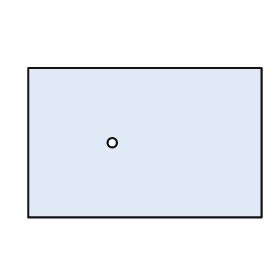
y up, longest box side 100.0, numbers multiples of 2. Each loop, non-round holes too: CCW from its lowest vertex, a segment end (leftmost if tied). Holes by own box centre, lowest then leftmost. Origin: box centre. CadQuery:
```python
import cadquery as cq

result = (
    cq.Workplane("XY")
    .moveTo(-50.0, -32.0)
    .lineTo(50.0, -32.0)
    .lineTo(50.0, 32.0)
    .lineTo(-50.0, 32.0)
    .close()
    .moveTo(-14.0, 0.0)
    .circle(2.0)
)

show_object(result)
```